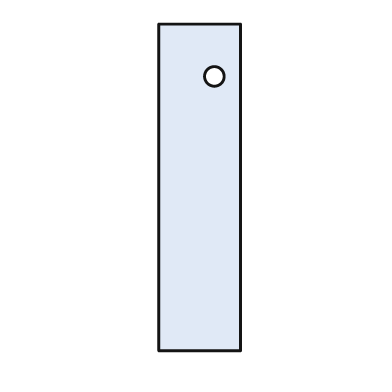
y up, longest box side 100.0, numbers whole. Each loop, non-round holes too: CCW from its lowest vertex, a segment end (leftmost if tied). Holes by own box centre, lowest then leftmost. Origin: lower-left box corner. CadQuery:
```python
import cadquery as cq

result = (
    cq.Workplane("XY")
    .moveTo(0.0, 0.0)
    .lineTo(25.0, 0.0)
    .lineTo(25.0, 100.0)
    .lineTo(0.0, 100.0)
    .close()
    .moveTo(17.0, 84.0)
    .circle(3.0)
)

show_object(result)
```